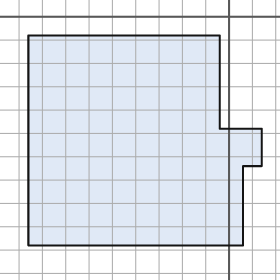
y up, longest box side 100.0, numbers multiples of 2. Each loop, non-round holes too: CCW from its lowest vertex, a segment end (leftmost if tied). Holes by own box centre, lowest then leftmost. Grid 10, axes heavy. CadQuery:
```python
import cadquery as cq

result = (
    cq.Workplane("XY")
    .moveTo(-86.0, -98.0)
    .lineTo(6.0, -98.0)
    .lineTo(6.0, -64.0)
    .lineTo(14.0, -64.0)
    .lineTo(14.0, -48.0)
    .lineTo(-4.0, -48.0)
    .lineTo(-4.0, -8.0)
    .lineTo(-86.0, -8.0)
    .close()
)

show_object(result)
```